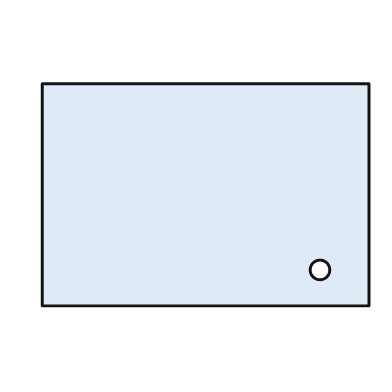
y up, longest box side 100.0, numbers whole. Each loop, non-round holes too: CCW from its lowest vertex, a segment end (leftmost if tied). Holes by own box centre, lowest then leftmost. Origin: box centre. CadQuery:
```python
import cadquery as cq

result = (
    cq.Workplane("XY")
    .moveTo(-50.0, -34.0)
    .lineTo(50.0, -34.0)
    .lineTo(50.0, 34.0)
    .lineTo(-50.0, 34.0)
    .close()
    .moveTo(35.0, -23.0)
    .circle(3.0)
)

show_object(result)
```